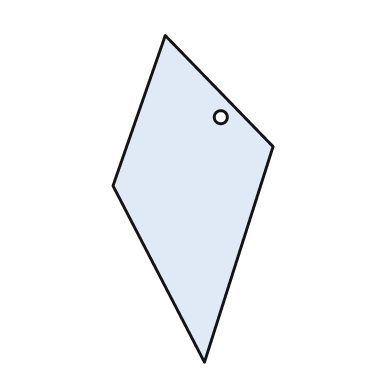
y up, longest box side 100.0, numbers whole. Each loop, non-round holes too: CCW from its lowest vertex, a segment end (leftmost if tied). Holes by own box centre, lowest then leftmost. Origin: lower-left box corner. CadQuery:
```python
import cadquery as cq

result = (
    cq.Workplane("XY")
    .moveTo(28.0, 0.0)
    .lineTo(49.0, 66.0)
    .lineTo(16.0, 100.0)
    .lineTo(0.0, 54.0)
    .close()
    .moveTo(33.0, 75.0)
    .circle(2.0)
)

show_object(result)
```